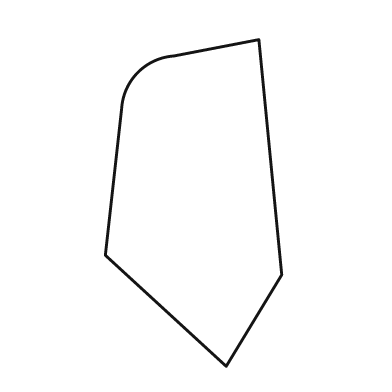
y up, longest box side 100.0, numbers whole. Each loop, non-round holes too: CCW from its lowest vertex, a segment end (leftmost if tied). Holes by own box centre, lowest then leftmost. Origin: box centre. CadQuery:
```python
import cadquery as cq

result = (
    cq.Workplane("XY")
    .moveTo(10.0, -50.0)
    .lineTo(27.0, -22.0)
    .lineTo(20.0, 50.0)
    .lineTo(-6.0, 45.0)
    .threePointArc((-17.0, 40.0), (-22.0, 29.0))
    .lineTo(-27.0, -16.0)
    .close()
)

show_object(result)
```